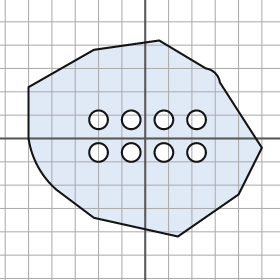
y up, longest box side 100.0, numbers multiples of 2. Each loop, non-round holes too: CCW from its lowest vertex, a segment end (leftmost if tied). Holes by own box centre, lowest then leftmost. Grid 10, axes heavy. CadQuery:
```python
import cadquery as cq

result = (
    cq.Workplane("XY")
    .moveTo(14.0, -42.0)
    .lineTo(40.0, -24.0)
    .lineTo(50.0, -4.0)
    .lineTo(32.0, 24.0)
    .threePointArc((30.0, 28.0), (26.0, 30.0))
    .lineTo(6.0, 42.0)
    .lineTo(-22.0, 38.0)
    .lineTo(-50.0, 22.0)
    .lineTo(-50.0, 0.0)
    .threePointArc((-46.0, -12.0), (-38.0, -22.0))
    .lineTo(-22.0, -34.0)
    .close()
    .moveTo(-20.0, -6.0)
    .circle(4.0)
    .moveTo(-6.0, -6.0)
    .circle(4.0)
    .moveTo(8.0, -6.0)
    .circle(4.0)
    .moveTo(22.0, -6.0)
    .circle(4.0)
    .moveTo(-20.0, 8.0)
    .circle(4.0)
    .moveTo(-6.0, 8.0)
    .circle(4.0)
    .moveTo(8.0, 8.0)
    .circle(4.0)
    .moveTo(22.0, 8.0)
    .circle(4.0)
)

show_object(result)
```